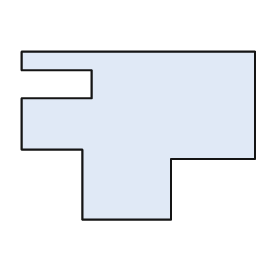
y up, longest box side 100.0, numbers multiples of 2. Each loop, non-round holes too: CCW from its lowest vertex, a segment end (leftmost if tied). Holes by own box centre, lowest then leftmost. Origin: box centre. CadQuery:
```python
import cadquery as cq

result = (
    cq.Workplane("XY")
    .moveTo(-24.0, -36.0)
    .lineTo(14.0, -36.0)
    .lineTo(14.0, -10.0)
    .lineTo(50.0, -10.0)
    .lineTo(50.0, 36.0)
    .lineTo(-50.0, 36.0)
    .lineTo(-50.0, 28.0)
    .lineTo(-20.0, 28.0)
    .lineTo(-20.0, 16.0)
    .lineTo(-50.0, 16.0)
    .lineTo(-50.0, -6.0)
    .lineTo(-24.0, -6.0)
    .close()
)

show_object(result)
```